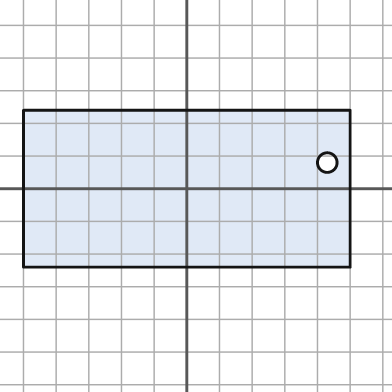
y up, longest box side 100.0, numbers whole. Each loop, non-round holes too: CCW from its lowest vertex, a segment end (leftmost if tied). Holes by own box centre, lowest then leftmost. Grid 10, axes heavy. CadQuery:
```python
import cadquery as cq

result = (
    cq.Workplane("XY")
    .moveTo(-50.0, -24.0)
    .lineTo(50.0, -24.0)
    .lineTo(50.0, 24.0)
    .lineTo(-50.0, 24.0)
    .close()
    .moveTo(43.0, 8.0)
    .circle(3.0)
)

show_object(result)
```